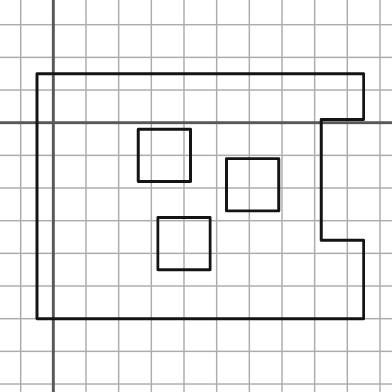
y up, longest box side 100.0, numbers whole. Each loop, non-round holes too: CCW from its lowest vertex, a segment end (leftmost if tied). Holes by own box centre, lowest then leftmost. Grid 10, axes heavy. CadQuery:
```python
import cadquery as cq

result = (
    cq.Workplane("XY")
    .moveTo(-5.0, -60.0)
    .lineTo(95.0, -60.0)
    .lineTo(95.0, -36.0)
    .lineTo(82.0, -36.0)
    .lineTo(82.0, 1.0)
    .lineTo(95.0, 1.0)
    .lineTo(95.0, 15.0)
    .lineTo(-5.0, 15.0)
    .close()
    .moveTo(32.0, -45.0)
    .lineTo(48.0, -45.0)
    .lineTo(48.0, -29.0)
    .lineTo(32.0, -29.0)
    .close()
    .moveTo(53.0, -27.0)
    .lineTo(69.0, -27.0)
    .lineTo(69.0, -11.0)
    .lineTo(53.0, -11.0)
    .close()
    .moveTo(26.0, -18.0)
    .lineTo(42.0, -18.0)
    .lineTo(42.0, -2.0)
    .lineTo(26.0, -2.0)
    .close()
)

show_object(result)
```